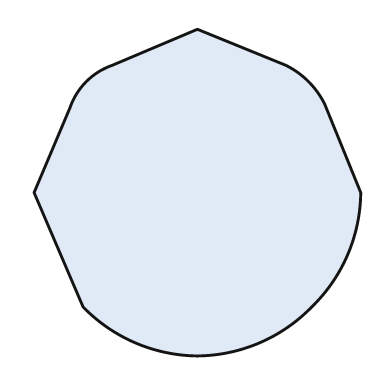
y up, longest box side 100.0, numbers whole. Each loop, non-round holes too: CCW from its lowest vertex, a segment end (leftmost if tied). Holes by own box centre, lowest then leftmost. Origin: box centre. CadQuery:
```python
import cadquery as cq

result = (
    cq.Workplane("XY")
    .moveTo(0.0, -50.0)
    .threePointArc((19.0, -46.0), (35.0, -35.0))
    .threePointArc((46.0, -19.0), (50.0, 0.0))
    .lineTo(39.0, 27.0)
    .threePointArc((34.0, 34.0), (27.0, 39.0))
    .lineTo(0.0, 50.0)
    .lineTo(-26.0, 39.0)
    .threePointArc((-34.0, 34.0), (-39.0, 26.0))
    .lineTo(-50.0, 0.0)
    .lineTo(-35.0, -35.0)
    .threePointArc((-19.0, -46.0), (0.0, -50.0))
    .close()
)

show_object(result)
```